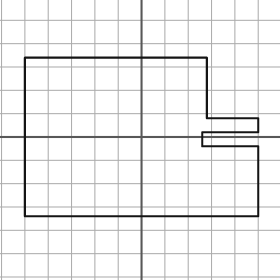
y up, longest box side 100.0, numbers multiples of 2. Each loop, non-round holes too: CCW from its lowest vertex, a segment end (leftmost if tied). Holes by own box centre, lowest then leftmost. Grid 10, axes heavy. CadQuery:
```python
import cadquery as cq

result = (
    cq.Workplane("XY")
    .moveTo(-50.0, -34.0)
    .lineTo(50.0, -34.0)
    .lineTo(50.0, -4.0)
    .lineTo(26.0, -4.0)
    .lineTo(26.0, 2.0)
    .lineTo(50.0, 2.0)
    .lineTo(50.0, 8.0)
    .lineTo(28.0, 8.0)
    .lineTo(28.0, 34.0)
    .lineTo(-50.0, 34.0)
    .close()
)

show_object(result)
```